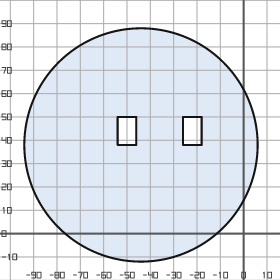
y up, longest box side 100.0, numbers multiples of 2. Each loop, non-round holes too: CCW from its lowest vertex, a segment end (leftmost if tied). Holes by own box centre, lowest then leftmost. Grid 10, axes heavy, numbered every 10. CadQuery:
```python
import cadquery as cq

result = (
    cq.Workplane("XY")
    .moveTo(-44.0, 38.0)
    .circle(50.0)
    .moveTo(-54.0, 38.0)
    .lineTo(-46.0, 38.0)
    .lineTo(-46.0, 50.0)
    .lineTo(-54.0, 50.0)
    .close()
    .moveTo(-26.0, 38.0)
    .lineTo(-18.0, 38.0)
    .lineTo(-18.0, 50.0)
    .lineTo(-26.0, 50.0)
    .close()
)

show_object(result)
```